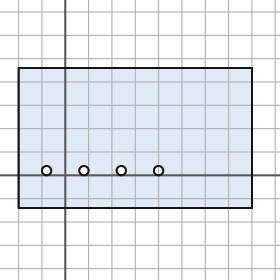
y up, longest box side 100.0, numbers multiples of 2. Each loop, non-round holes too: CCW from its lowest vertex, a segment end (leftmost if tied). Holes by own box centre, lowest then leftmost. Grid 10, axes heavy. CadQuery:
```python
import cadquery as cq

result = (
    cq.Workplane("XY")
    .moveTo(-20.0, -14.0)
    .lineTo(80.0, -14.0)
    .lineTo(80.0, 46.0)
    .lineTo(-20.0, 46.0)
    .close()
    .moveTo(-8.0, 2.0)
    .circle(2.0)
    .moveTo(8.0, 2.0)
    .circle(2.0)
    .moveTo(24.0, 2.0)
    .circle(2.0)
    .moveTo(40.0, 2.0)
    .circle(2.0)
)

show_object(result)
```